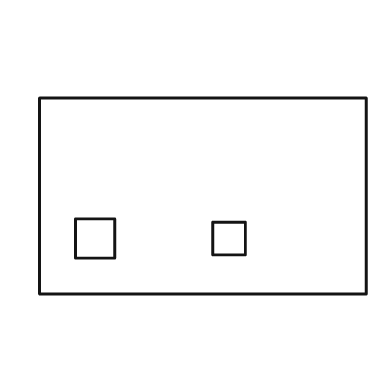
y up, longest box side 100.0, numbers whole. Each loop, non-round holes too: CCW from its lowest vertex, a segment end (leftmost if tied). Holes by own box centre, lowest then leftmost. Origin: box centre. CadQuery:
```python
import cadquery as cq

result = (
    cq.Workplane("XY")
    .moveTo(-50.0, -30.0)
    .lineTo(50.0, -30.0)
    .lineTo(50.0, 30.0)
    .lineTo(-50.0, 30.0)
    .close()
    .moveTo(-39.0, -19.0)
    .lineTo(-27.0, -19.0)
    .lineTo(-27.0, -7.0)
    .lineTo(-39.0, -7.0)
    .close()
    .moveTo(3.0, -18.0)
    .lineTo(13.0, -18.0)
    .lineTo(13.0, -8.0)
    .lineTo(3.0, -8.0)
    .close()
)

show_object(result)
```